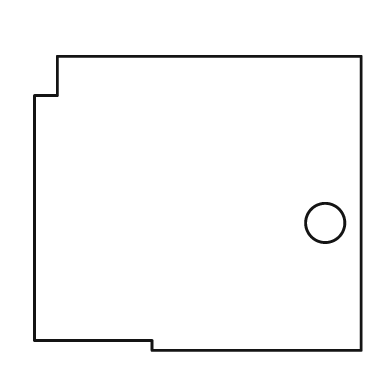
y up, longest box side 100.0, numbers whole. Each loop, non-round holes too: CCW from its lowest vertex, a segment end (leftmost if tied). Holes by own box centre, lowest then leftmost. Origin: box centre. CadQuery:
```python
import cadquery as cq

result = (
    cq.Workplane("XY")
    .moveTo(-14.0, -45.0)
    .lineTo(50.0, -45.0)
    .lineTo(50.0, 45.0)
    .lineTo(-43.0, 45.0)
    .lineTo(-43.0, 33.0)
    .lineTo(-50.0, 33.0)
    .lineTo(-50.0, -42.0)
    .lineTo(-14.0, -42.0)
    .close()
    .moveTo(39.0, -6.0)
    .circle(6.0)
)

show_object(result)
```